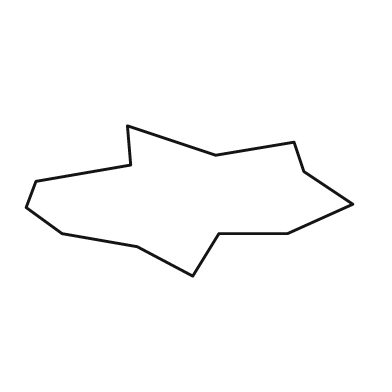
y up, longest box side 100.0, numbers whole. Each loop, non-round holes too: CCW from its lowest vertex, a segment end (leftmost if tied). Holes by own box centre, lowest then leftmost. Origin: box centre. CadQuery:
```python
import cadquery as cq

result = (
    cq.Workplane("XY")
    .moveTo(1.0, -23.0)
    .lineTo(9.0, -10.0)
    .lineTo(30.0, -10.0)
    .lineTo(50.0, -1.0)
    .lineTo(35.0, 9.0)
    .lineTo(32.0, 18.0)
    .lineTo(8.0, 14.0)
    .lineTo(-19.0, 23.0)
    .lineTo(-18.0, 11.0)
    .lineTo(-47.0, 6.0)
    .lineTo(-50.0, -2.0)
    .lineTo(-39.0, -10.0)
    .lineTo(-16.0, -14.0)
    .close()
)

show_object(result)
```